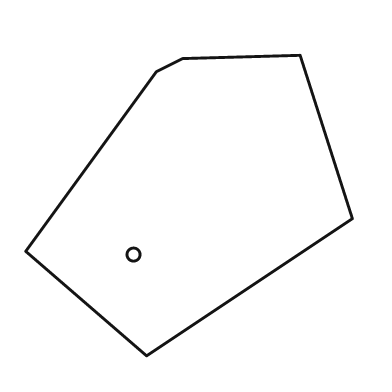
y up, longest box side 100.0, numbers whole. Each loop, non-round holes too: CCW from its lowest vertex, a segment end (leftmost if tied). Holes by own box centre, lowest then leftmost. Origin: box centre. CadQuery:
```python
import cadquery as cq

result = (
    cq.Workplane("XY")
    .moveTo(-13.0, -46.0)
    .lineTo(50.0, -4.0)
    .lineTo(34.0, 46.0)
    .lineTo(-2.0, 45.0)
    .lineTo(-10.0, 41.0)
    .lineTo(-50.0, -14.0)
    .close()
    .moveTo(-17.0, -15.0)
    .circle(2.0)
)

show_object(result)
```